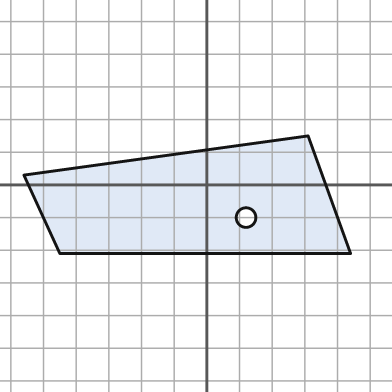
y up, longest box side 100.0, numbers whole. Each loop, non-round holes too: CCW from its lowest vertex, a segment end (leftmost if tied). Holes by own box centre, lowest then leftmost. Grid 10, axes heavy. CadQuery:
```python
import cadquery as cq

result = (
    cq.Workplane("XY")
    .moveTo(-45.0, -21.0)
    .lineTo(44.0, -21.0)
    .lineTo(31.0, 15.0)
    .lineTo(-56.0, 3.0)
    .close()
    .moveTo(12.0, -10.0)
    .circle(3.0)
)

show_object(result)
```